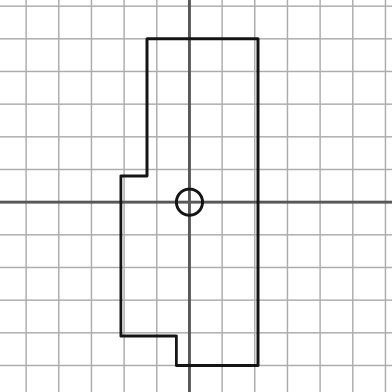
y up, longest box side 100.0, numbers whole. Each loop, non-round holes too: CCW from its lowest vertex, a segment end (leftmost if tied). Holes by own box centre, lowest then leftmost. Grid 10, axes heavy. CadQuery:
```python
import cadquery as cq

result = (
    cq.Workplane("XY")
    .moveTo(-4.0, -50.0)
    .lineTo(21.0, -50.0)
    .lineTo(21.0, 50.0)
    .lineTo(-13.0, 50.0)
    .lineTo(-13.0, 8.0)
    .lineTo(-21.0, 8.0)
    .lineTo(-21.0, -41.0)
    .lineTo(-4.0, -41.0)
    .close()
    .moveTo(0.0, 0.0)
    .circle(4.0)
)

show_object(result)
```